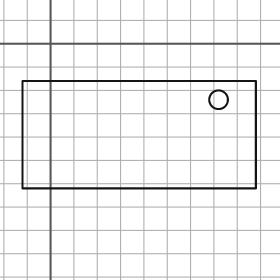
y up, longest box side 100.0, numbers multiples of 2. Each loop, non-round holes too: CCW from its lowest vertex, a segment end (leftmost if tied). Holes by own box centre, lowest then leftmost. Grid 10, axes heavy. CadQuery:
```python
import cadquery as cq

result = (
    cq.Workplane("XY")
    .moveTo(-12.0, -62.0)
    .lineTo(88.0, -62.0)
    .lineTo(88.0, -16.0)
    .lineTo(-12.0, -16.0)
    .close()
    .moveTo(72.0, -24.0)
    .circle(4.0)
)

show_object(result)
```